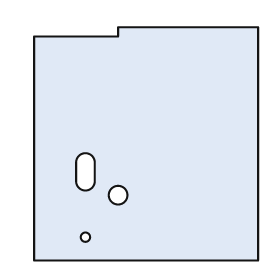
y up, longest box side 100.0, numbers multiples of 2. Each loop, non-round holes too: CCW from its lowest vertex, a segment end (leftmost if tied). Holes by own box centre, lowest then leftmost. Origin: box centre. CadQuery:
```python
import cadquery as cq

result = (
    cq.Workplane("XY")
    .moveTo(-48.0, -50.0)
    .lineTo(48.0, -50.0)
    .lineTo(48.0, 50.0)
    .lineTo(-12.0, 50.0)
    .lineTo(-12.0, 46.0)
    .lineTo(-48.0, 46.0)
    .close()
    .moveTo(-26.0, -40.0)
    .circle(2.0)
    .moveTo(-12.0, -22.0)
    .circle(4.0)
    .moveTo(-30.0, -16.0)
    .threePointArc((-26.0, -20.0), (-22.0, -16.0))
    .lineTo(-22.0, -8.0)
    .threePointArc((-26.0, -4.0), (-30.0, -8.0))
    .close()
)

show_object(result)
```